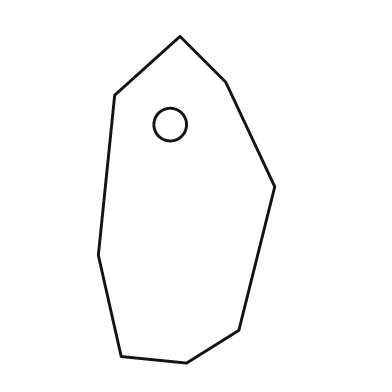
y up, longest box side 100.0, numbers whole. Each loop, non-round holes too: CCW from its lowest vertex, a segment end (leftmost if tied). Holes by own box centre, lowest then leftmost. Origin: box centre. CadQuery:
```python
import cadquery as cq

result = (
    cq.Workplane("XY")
    .moveTo(0.0, -50.0)
    .lineTo(16.0, -40.0)
    .lineTo(27.0, 4.0)
    .lineTo(12.0, 36.0)
    .lineTo(-2.0, 50.0)
    .lineTo(-22.0, 32.0)
    .lineTo(-27.0, -17.0)
    .lineTo(-20.0, -48.0)
    .close()
    .moveTo(-5.0, 23.0)
    .circle(5.0)
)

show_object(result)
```